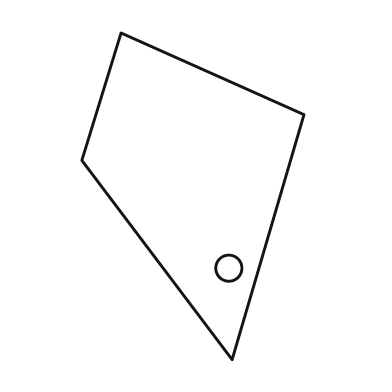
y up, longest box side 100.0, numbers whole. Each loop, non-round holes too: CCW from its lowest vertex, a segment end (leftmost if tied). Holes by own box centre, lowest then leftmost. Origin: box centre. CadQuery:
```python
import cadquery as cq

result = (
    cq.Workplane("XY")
    .moveTo(12.0, -50.0)
    .lineTo(34.0, 25.0)
    .lineTo(-22.0, 50.0)
    .lineTo(-34.0, 11.0)
    .close()
    .moveTo(11.0, -22.0)
    .circle(4.0)
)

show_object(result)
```